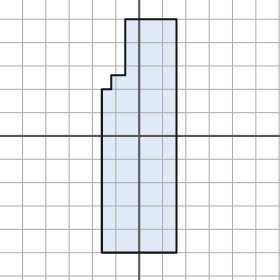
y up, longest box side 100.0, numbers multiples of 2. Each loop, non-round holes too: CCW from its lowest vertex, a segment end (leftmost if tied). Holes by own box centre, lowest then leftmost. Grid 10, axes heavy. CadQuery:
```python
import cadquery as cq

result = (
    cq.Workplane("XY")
    .moveTo(-16.0, -50.0)
    .lineTo(16.0, -50.0)
    .lineTo(16.0, 50.0)
    .lineTo(-6.0, 50.0)
    .lineTo(-6.0, 26.0)
    .lineTo(-12.0, 26.0)
    .lineTo(-12.0, 20.0)
    .lineTo(-16.0, 20.0)
    .close()
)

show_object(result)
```